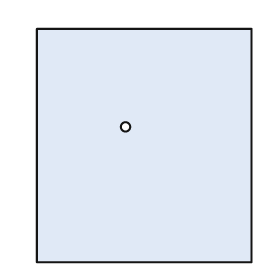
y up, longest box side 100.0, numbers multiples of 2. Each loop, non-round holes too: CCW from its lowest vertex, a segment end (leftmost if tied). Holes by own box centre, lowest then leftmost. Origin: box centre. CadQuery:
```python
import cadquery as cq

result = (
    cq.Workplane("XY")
    .moveTo(-46.0, -50.0)
    .lineTo(46.0, -50.0)
    .lineTo(46.0, 50.0)
    .lineTo(-46.0, 50.0)
    .close()
    .moveTo(-8.0, 8.0)
    .circle(2.0)
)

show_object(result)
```